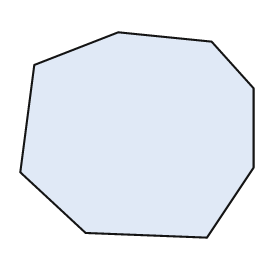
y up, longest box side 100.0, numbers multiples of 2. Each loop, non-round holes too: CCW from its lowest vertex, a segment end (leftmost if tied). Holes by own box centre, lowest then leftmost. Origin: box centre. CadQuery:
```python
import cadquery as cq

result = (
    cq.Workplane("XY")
    .moveTo(30.0, -44.0)
    .lineTo(50.0, -14.0)
    .lineTo(50.0, 20.0)
    .lineTo(32.0, 40.0)
    .lineTo(-8.0, 44.0)
    .lineTo(-44.0, 30.0)
    .lineTo(-50.0, -16.0)
    .lineTo(-22.0, -42.0)
    .close()
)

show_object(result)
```